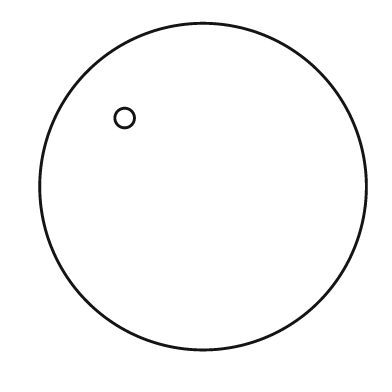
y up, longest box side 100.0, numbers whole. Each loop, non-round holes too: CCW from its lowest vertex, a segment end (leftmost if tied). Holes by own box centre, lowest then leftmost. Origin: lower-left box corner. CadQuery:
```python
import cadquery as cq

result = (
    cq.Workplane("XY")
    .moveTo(50.0, 50.0)
    .circle(50.0)
    .moveTo(26.0, 71.0)
    .circle(3.0)
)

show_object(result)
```